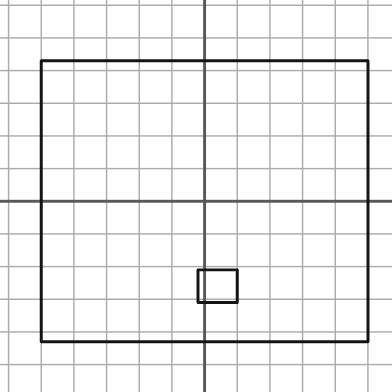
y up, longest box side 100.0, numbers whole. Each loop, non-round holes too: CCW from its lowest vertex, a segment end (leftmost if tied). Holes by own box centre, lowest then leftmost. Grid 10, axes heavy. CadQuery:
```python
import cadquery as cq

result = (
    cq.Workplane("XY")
    .moveTo(-50.0, -43.0)
    .lineTo(50.0, -43.0)
    .lineTo(50.0, 43.0)
    .lineTo(-50.0, 43.0)
    .close()
    .moveTo(-2.0, -31.0)
    .lineTo(10.0, -31.0)
    .lineTo(10.0, -21.0)
    .lineTo(-2.0, -21.0)
    .close()
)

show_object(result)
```